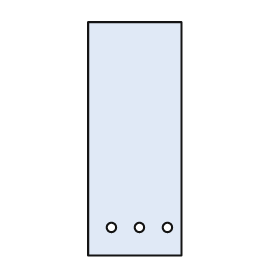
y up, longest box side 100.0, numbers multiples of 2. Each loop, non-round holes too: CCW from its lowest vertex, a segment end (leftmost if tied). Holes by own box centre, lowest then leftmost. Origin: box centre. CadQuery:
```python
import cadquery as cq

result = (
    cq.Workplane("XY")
    .moveTo(-20.0, -50.0)
    .lineTo(20.0, -50.0)
    .lineTo(20.0, 50.0)
    .lineTo(-20.0, 50.0)
    .close()
    .moveTo(-10.0, -38.0)
    .circle(2.0)
    .moveTo(2.0, -38.0)
    .circle(2.0)
    .moveTo(14.0, -38.0)
    .circle(2.0)
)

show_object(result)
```